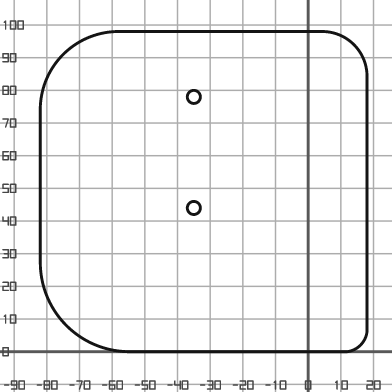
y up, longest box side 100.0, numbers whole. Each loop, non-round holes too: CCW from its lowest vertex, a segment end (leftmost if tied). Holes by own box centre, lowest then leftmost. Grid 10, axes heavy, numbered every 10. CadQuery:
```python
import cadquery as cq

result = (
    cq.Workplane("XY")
    .moveTo(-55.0, 0.0)
    .lineTo(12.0, 0.0)
    .threePointArc((16.0, 2.0), (18.0, 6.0))
    .lineTo(18.0, 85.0)
    .threePointArc((14.0, 94.0), (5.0, 98.0))
    .lineTo(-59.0, 98.0)
    .threePointArc((-75.0, 91.0), (-82.0, 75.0))
    .lineTo(-82.0, 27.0)
    .threePointArc((-74.0, 8.0), (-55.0, 0.0))
    .close()
    .moveTo(-35.0, 44.0)
    .circle(2.0)
    .moveTo(-35.0, 78.0)
    .circle(2.0)
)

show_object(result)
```